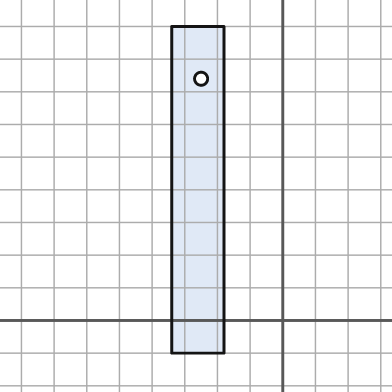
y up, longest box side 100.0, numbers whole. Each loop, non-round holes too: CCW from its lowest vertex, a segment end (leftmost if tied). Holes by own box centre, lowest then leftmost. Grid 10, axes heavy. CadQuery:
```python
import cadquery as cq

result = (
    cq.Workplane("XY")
    .moveTo(-34.0, -10.0)
    .lineTo(-18.0, -10.0)
    .lineTo(-18.0, 90.0)
    .lineTo(-34.0, 90.0)
    .close()
    .moveTo(-25.0, 74.0)
    .circle(2.0)
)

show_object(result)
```